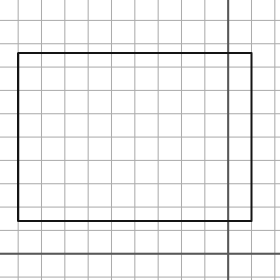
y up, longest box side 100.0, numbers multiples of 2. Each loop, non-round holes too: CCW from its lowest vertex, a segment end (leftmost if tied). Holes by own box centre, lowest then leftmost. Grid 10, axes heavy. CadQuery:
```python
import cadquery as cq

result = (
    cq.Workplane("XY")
    .moveTo(-90.0, 14.0)
    .lineTo(10.0, 14.0)
    .lineTo(10.0, 86.0)
    .lineTo(-90.0, 86.0)
    .close()
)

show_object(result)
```